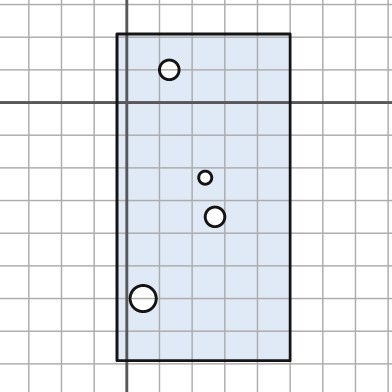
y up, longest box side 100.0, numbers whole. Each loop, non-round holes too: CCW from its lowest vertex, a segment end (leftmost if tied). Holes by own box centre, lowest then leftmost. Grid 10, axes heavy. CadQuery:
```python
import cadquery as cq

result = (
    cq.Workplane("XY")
    .moveTo(-3.0, -79.0)
    .lineTo(50.0, -79.0)
    .lineTo(50.0, 21.0)
    .lineTo(-3.0, 21.0)
    .close()
    .moveTo(5.0, -60.0)
    .circle(4.0)
    .moveTo(27.0, -35.0)
    .circle(3.0)
    .moveTo(24.0, -23.0)
    .circle(2.0)
    .moveTo(13.0, 10.0)
    .circle(3.0)
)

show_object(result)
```